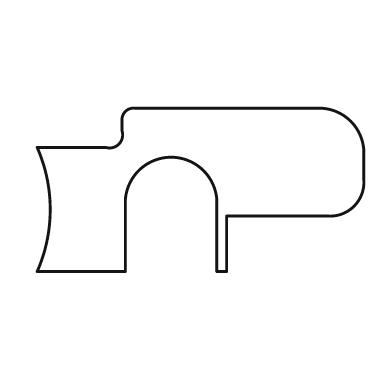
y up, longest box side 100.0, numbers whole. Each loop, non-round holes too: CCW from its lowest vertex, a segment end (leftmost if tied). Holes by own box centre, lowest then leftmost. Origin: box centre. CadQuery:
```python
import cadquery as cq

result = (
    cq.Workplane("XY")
    .moveTo(-50.0, -25.0)
    .lineTo(-23.0, -25.0)
    .lineTo(-23.0, -3.0)
    .threePointArc((-9.0, 10.0), (5.0, -3.0))
    .lineTo(5.0, -25.0)
    .lineTo(8.0, -25.0)
    .lineTo(8.0, -8.0)
    .lineTo(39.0, -8.0)
    .threePointArc((47.0, -5.0), (50.0, 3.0))
    .lineTo(50.0, 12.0)
    .threePointArc((46.0, 21.0), (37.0, 25.0))
    .lineTo(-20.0, 25.0)
    .threePointArc((-23.0, 24.0), (-24.0, 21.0))
    .lineTo(-24.0, 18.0)
    .threePointArc((-25.0, 14.0), (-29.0, 13.0))
    .lineTo(-50.0, 13.0)
    .threePointArc((-46.0, -6.0), (-50.0, -25.0))
    .close()
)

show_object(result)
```